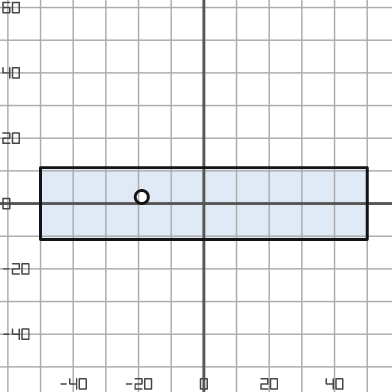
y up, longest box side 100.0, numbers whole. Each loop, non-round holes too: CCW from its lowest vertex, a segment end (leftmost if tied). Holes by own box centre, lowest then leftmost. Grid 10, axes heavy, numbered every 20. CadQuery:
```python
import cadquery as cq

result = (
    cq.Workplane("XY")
    .moveTo(-50.0, -11.0)
    .lineTo(50.0, -11.0)
    .lineTo(50.0, 11.0)
    .lineTo(-50.0, 11.0)
    .close()
    .moveTo(-19.0, 2.0)
    .circle(2.0)
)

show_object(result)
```